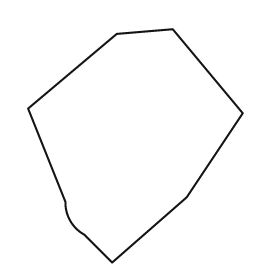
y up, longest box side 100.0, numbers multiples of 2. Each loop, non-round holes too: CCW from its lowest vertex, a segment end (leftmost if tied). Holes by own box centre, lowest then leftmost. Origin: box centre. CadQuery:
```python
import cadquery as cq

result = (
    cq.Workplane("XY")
    .moveTo(-10.0, -50.0)
    .lineTo(22.0, -22.0)
    .lineTo(46.0, 14.0)
    .lineTo(16.0, 50.0)
    .lineTo(-8.0, 48.0)
    .lineTo(-46.0, 16.0)
    .lineTo(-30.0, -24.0)
    .threePointArc((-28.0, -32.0), (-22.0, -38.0))
    .close()
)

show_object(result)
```